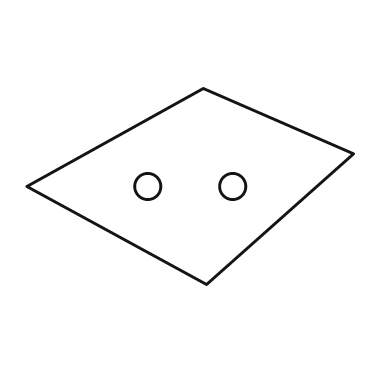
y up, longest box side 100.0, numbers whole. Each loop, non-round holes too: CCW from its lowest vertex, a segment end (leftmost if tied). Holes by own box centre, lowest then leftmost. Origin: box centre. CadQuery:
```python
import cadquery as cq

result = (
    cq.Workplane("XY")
    .moveTo(5.0, -30.0)
    .lineTo(50.0, 10.0)
    .lineTo(4.0, 30.0)
    .lineTo(-50.0, 0.0)
    .close()
    .moveTo(-13.0, 0.0)
    .circle(4.0)
    .moveTo(13.0, 0.0)
    .circle(4.0)
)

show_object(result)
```